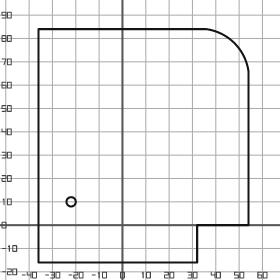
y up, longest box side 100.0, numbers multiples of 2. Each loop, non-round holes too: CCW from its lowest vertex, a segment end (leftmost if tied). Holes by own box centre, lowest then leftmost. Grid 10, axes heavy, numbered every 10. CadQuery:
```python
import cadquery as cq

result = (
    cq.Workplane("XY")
    .moveTo(-36.0, -16.0)
    .lineTo(32.0, -16.0)
    .lineTo(32.0, 0.0)
    .lineTo(54.0, 0.0)
    .lineTo(54.0, 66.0)
    .threePointArc((48.0, 78.0), (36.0, 84.0))
    .lineTo(-36.0, 84.0)
    .close()
    .moveTo(-22.0, 10.0)
    .circle(2.0)
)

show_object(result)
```